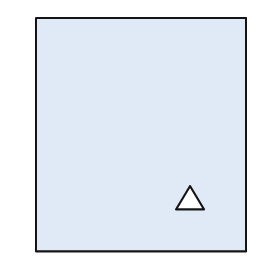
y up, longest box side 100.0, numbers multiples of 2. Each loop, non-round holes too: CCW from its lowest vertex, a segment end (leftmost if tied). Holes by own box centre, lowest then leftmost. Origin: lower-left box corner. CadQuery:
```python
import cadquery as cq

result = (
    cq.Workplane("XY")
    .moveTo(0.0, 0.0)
    .lineTo(90.0, 0.0)
    .lineTo(90.0, 100.0)
    .lineTo(0.0, 100.0)
    .close()
    .moveTo(60.0, 18.0)
    .lineTo(72.0, 18.0)
    .lineTo(66.0, 28.0)
    .close()
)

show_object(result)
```